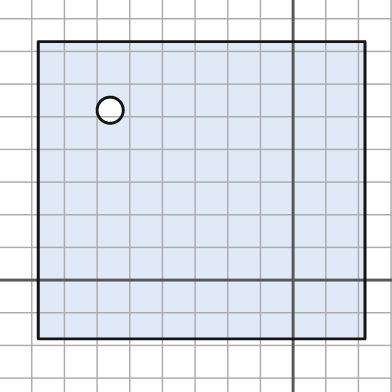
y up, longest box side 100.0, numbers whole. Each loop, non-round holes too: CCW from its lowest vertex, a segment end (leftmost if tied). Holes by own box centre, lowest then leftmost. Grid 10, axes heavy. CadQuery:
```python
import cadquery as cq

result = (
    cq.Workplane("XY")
    .moveTo(-78.0, -18.0)
    .lineTo(22.0, -18.0)
    .lineTo(22.0, 73.0)
    .lineTo(-78.0, 73.0)
    .close()
    .moveTo(-56.0, 52.0)
    .circle(4.0)
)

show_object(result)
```